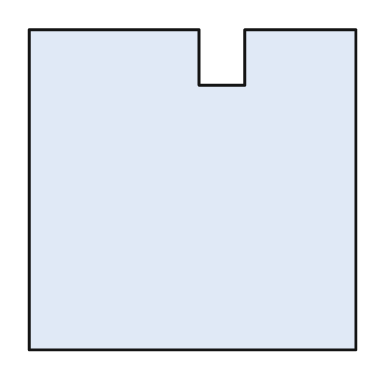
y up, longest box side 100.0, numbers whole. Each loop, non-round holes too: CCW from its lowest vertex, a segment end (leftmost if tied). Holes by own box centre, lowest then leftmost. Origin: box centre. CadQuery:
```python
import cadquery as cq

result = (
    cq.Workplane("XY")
    .moveTo(-50.0, -49.0)
    .lineTo(50.0, -49.0)
    .lineTo(50.0, 49.0)
    .lineTo(16.0, 49.0)
    .lineTo(16.0, 32.0)
    .lineTo(2.0, 32.0)
    .lineTo(2.0, 49.0)
    .lineTo(-50.0, 49.0)
    .close()
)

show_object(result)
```